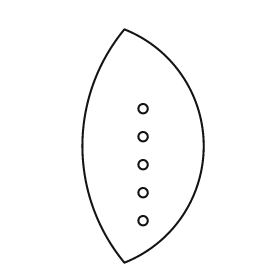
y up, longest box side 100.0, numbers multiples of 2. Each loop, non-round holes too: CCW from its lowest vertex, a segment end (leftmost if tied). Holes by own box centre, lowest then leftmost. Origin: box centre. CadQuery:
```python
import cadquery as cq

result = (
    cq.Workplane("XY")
    .moveTo(-8.0, -50.0)
    .threePointArc((26.0, 0.0), (-8.0, 50.0))
    .threePointArc((-26.0, 0.0), (-8.0, -50.0))
    .close()
    .moveTo(0.0, -32.0)
    .circle(2.0)
    .moveTo(0.0, -20.0)
    .circle(2.0)
    .moveTo(0.0, -8.0)
    .circle(2.0)
    .moveTo(0.0, 4.0)
    .circle(2.0)
    .moveTo(0.0, 16.0)
    .circle(2.0)
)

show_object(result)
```